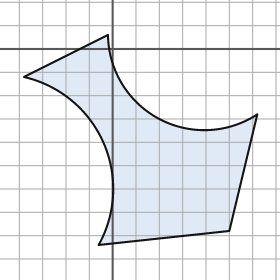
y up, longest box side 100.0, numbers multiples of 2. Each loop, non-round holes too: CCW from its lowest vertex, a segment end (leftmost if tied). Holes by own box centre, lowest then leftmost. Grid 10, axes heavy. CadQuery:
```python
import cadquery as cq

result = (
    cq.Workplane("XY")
    .moveTo(-6.0, -84.0)
    .lineTo(50.0, -78.0)
    .lineTo(62.0, -28.0)
    .threePointArc((20.0, -30.0), (-2.0, 6.0))
    .lineTo(-38.0, -12.0)
    .threePointArc((-4.0, -40.0), (-6.0, -84.0))
    .close()
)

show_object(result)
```